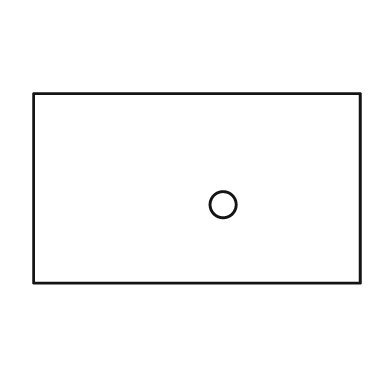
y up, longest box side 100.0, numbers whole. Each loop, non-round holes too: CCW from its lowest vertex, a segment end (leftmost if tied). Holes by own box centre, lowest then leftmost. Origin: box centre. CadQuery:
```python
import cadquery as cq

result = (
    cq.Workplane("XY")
    .moveTo(-50.0, -29.0)
    .lineTo(50.0, -29.0)
    .lineTo(50.0, 29.0)
    .lineTo(-50.0, 29.0)
    .close()
    .moveTo(8.0, -5.0)
    .circle(4.0)
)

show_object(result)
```